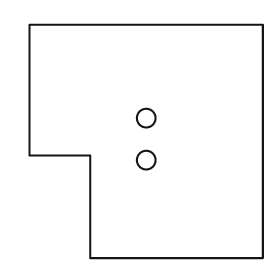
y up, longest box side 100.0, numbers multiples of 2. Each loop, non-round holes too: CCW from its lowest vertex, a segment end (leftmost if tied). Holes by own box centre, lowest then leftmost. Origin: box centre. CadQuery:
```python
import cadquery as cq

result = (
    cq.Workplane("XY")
    .moveTo(-24.0, -50.0)
    .lineTo(50.0, -50.0)
    .lineTo(50.0, 50.0)
    .lineTo(-50.0, 50.0)
    .lineTo(-50.0, -6.0)
    .lineTo(-24.0, -6.0)
    .close()
    .moveTo(0.0, -8.0)
    .circle(4.0)
    .moveTo(0.0, 10.0)
    .circle(4.0)
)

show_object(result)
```